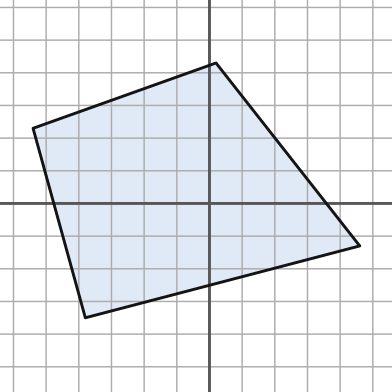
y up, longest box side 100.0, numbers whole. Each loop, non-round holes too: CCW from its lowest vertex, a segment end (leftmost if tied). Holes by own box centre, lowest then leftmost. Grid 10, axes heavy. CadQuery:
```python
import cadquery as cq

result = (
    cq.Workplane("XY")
    .moveTo(-38.0, -35.0)
    .lineTo(46.0, -13.0)
    .lineTo(2.0, 43.0)
    .lineTo(-54.0, 23.0)
    .close()
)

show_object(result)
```